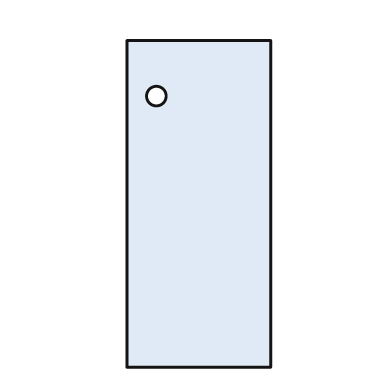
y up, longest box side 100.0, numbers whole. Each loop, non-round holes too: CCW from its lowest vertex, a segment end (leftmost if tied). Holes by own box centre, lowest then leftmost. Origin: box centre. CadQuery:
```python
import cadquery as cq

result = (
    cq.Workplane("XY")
    .moveTo(-22.0, -50.0)
    .lineTo(22.0, -50.0)
    .lineTo(22.0, 50.0)
    .lineTo(-22.0, 50.0)
    .close()
    .moveTo(-13.0, 33.0)
    .circle(3.0)
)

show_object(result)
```